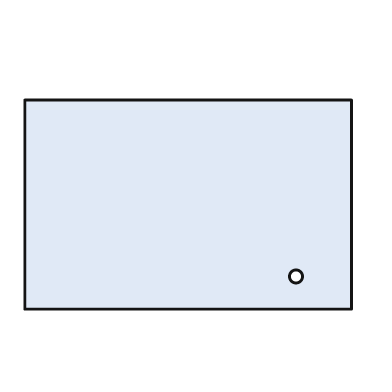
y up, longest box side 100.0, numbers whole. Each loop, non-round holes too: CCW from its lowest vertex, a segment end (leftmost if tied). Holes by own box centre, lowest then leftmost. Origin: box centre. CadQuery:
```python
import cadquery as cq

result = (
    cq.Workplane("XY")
    .moveTo(-50.0, -32.0)
    .lineTo(50.0, -32.0)
    .lineTo(50.0, 32.0)
    .lineTo(-50.0, 32.0)
    .close()
    .moveTo(33.0, -22.0)
    .circle(2.0)
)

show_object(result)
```